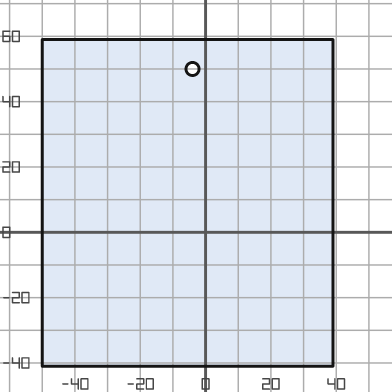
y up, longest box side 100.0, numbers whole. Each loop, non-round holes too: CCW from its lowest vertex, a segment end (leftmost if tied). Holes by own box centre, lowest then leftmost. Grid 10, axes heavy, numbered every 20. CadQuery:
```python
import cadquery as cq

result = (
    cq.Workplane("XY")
    .moveTo(-50.0, -41.0)
    .lineTo(39.0, -41.0)
    .lineTo(39.0, 59.0)
    .lineTo(-50.0, 59.0)
    .close()
    .moveTo(-4.0, 50.0)
    .circle(2.0)
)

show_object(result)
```